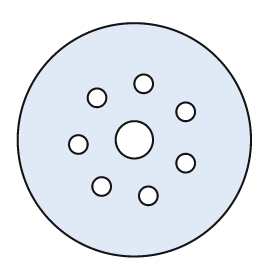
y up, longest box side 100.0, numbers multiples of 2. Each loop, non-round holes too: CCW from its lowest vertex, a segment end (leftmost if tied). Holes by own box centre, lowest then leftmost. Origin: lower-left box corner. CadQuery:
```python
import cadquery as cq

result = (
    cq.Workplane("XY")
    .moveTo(50.0, 50.0)
    .circle(50.0)
    .moveTo(56.0, 26.0)
    .circle(4.0)
    .moveTo(36.0, 30.0)
    .circle(4.0)
    .moveTo(72.0, 40.0)
    .circle(4.0)
    .moveTo(26.0, 48.0)
    .circle(4.0)
    .moveTo(50.0, 50.0)
    .circle(8.0)
    .moveTo(72.0, 62.0)
    .circle(4.0)
    .moveTo(34.0, 68.0)
    .circle(4.0)
    .moveTo(54.0, 74.0)
    .circle(4.0)
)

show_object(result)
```